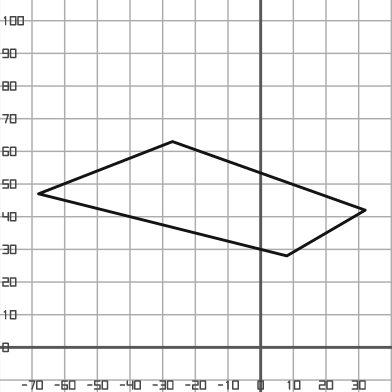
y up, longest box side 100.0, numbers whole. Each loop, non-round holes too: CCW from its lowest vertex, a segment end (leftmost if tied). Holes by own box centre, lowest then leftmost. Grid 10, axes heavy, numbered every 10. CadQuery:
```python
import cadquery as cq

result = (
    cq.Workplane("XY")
    .moveTo(8.0, 28.0)
    .lineTo(32.0, 42.0)
    .lineTo(-27.0, 63.0)
    .lineTo(-68.0, 47.0)
    .close()
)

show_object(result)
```